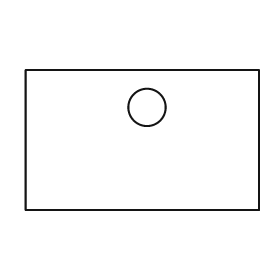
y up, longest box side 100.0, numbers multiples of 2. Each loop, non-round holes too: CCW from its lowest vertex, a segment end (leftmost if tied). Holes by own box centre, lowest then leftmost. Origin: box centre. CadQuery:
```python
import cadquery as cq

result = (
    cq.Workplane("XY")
    .moveTo(-50.0, -30.0)
    .lineTo(50.0, -30.0)
    .lineTo(50.0, 30.0)
    .lineTo(-50.0, 30.0)
    .close()
    .moveTo(2.0, 14.0)
    .circle(8.0)
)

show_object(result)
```